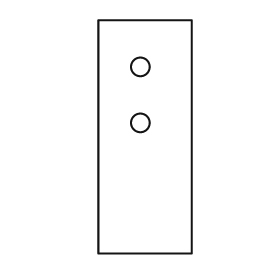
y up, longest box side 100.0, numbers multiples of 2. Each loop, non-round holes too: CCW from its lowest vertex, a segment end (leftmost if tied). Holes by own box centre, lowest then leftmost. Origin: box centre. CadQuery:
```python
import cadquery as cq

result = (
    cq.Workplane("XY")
    .moveTo(-20.0, -50.0)
    .lineTo(20.0, -50.0)
    .lineTo(20.0, 50.0)
    .lineTo(-20.0, 50.0)
    .close()
    .moveTo(-2.0, 6.0)
    .circle(4.0)
    .moveTo(-2.0, 30.0)
    .circle(4.0)
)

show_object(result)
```